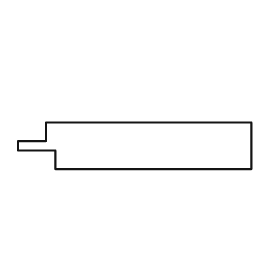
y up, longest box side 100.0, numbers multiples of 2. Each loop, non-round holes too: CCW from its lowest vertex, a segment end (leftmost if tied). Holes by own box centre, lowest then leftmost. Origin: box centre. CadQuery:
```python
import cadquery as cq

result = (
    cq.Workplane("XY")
    .moveTo(-34.0, -10.0)
    .lineTo(50.0, -10.0)
    .lineTo(50.0, 10.0)
    .lineTo(-38.0, 10.0)
    .lineTo(-38.0, 2.0)
    .lineTo(-50.0, 2.0)
    .lineTo(-50.0, -2.0)
    .lineTo(-34.0, -2.0)
    .close()
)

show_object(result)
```